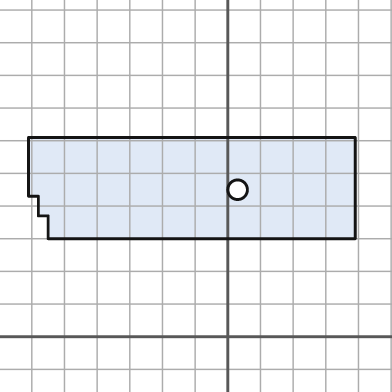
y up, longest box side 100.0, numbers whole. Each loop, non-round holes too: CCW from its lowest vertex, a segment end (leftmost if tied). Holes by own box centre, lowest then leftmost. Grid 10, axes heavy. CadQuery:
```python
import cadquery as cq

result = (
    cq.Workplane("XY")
    .moveTo(-55.0, 30.0)
    .lineTo(39.0, 30.0)
    .lineTo(39.0, 61.0)
    .lineTo(-61.0, 61.0)
    .lineTo(-61.0, 43.0)
    .lineTo(-58.0, 43.0)
    .lineTo(-58.0, 37.0)
    .lineTo(-55.0, 37.0)
    .close()
    .moveTo(3.0, 45.0)
    .circle(3.0)
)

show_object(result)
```